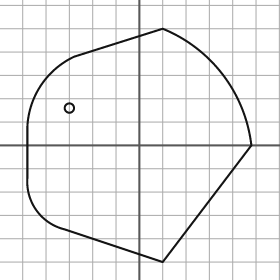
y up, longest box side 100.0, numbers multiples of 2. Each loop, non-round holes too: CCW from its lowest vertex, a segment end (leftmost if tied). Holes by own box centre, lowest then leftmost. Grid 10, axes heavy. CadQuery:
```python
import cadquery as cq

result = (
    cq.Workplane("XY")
    .moveTo(10.0, -50.0)
    .lineTo(48.0, 0.0)
    .threePointArc((36.0, 30.0), (10.0, 50.0))
    .lineTo(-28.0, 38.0)
    .threePointArc((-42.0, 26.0), (-48.0, 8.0))
    .lineTo(-48.0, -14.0)
    .threePointArc((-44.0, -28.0), (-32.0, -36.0))
    .close()
    .moveTo(-30.0, 16.0)
    .circle(2.0)
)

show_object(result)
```